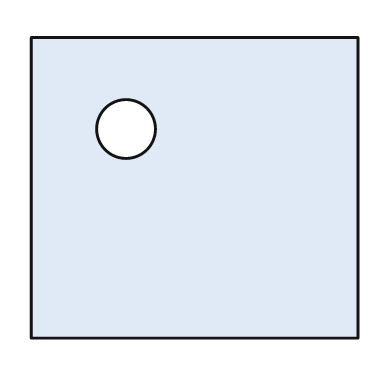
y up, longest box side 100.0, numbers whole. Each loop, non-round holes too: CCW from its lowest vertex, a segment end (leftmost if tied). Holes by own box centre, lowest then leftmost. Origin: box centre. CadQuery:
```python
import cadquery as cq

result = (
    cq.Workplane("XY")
    .moveTo(-50.0, -46.0)
    .lineTo(50.0, -46.0)
    .lineTo(50.0, 46.0)
    .lineTo(-50.0, 46.0)
    .close()
    .moveTo(-21.0, 18.0)
    .circle(9.0)
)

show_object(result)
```